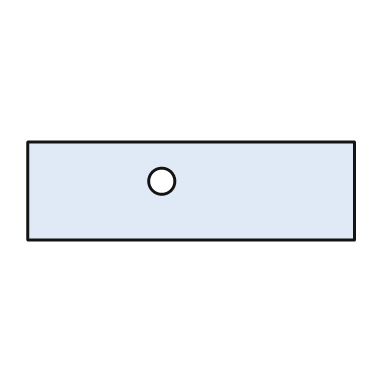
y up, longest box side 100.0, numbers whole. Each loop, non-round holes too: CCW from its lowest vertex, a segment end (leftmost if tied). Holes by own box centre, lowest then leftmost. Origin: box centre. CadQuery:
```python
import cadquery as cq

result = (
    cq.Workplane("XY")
    .moveTo(-50.0, -15.0)
    .lineTo(50.0, -15.0)
    .lineTo(50.0, 15.0)
    .lineTo(-50.0, 15.0)
    .close()
    .moveTo(-9.0, 3.0)
    .circle(4.0)
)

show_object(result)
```